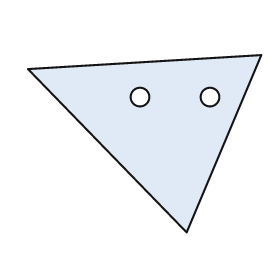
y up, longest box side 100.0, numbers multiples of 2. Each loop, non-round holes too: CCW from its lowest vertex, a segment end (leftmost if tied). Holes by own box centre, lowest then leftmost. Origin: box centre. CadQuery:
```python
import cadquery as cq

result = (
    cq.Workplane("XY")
    .moveTo(18.0, -38.0)
    .lineTo(50.0, 38.0)
    .lineTo(-50.0, 32.0)
    .close()
    .moveTo(-2.0, 20.0)
    .circle(4.0)
    .moveTo(28.0, 20.0)
    .circle(4.0)
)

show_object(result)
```